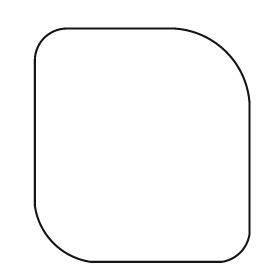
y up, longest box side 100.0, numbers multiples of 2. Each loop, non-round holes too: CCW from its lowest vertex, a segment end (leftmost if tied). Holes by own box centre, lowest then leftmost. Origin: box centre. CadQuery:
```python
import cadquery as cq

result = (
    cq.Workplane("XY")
    .moveTo(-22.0, -50.0)
    .lineTo(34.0, -50.0)
    .threePointArc((42.0, -46.0), (46.0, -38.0))
    .lineTo(46.0, 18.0)
    .threePointArc((36.0, 40.0), (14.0, 50.0))
    .lineTo(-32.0, 50.0)
    .threePointArc((-42.0, 46.0), (-46.0, 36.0))
    .lineTo(-46.0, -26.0)
    .threePointArc((-38.0, -42.0), (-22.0, -50.0))
    .close()
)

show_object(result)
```